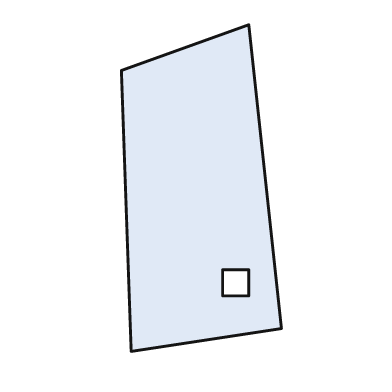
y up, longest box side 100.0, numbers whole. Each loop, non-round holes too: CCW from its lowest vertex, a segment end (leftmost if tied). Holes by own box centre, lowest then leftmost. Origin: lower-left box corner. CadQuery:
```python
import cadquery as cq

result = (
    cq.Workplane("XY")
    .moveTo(3.0, 0.0)
    .lineTo(49.0, 7.0)
    .lineTo(39.0, 100.0)
    .lineTo(0.0, 86.0)
    .close()
    .moveTo(31.0, 17.0)
    .lineTo(39.0, 17.0)
    .lineTo(39.0, 25.0)
    .lineTo(31.0, 25.0)
    .close()
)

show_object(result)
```